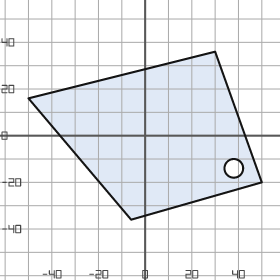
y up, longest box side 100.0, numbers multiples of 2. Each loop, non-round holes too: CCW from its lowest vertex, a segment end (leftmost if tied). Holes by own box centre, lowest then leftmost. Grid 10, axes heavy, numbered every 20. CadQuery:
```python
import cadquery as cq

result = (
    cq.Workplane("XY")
    .moveTo(-6.0, -36.0)
    .lineTo(50.0, -20.0)
    .lineTo(30.0, 36.0)
    .lineTo(-50.0, 16.0)
    .close()
    .moveTo(38.0, -14.0)
    .circle(4.0)
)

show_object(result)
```